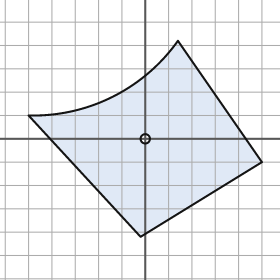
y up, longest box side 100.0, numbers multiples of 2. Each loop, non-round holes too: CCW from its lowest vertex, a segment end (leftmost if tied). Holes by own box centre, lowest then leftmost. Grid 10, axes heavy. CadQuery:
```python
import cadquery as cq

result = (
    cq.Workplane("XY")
    .moveTo(-2.0, -42.0)
    .lineTo(50.0, -10.0)
    .lineTo(14.0, 42.0)
    .threePointArc((-14.0, 18.0), (-50.0, 10.0))
    .close()
    .moveTo(0.0, 0.0)
    .circle(2.0)
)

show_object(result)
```